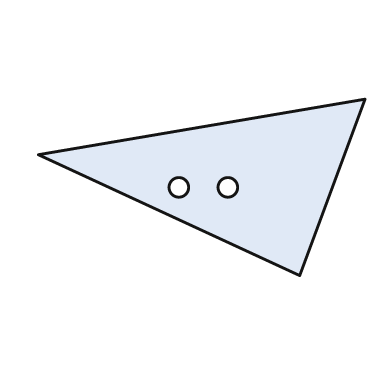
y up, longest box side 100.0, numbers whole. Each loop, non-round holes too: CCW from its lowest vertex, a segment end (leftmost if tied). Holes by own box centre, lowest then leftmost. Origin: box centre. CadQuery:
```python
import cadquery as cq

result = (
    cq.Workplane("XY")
    .moveTo(30.0, -27.0)
    .lineTo(50.0, 27.0)
    .lineTo(-50.0, 10.0)
    .close()
    .moveTo(-7.0, 0.0)
    .circle(3.0)
    .moveTo(8.0, 0.0)
    .circle(3.0)
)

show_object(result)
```